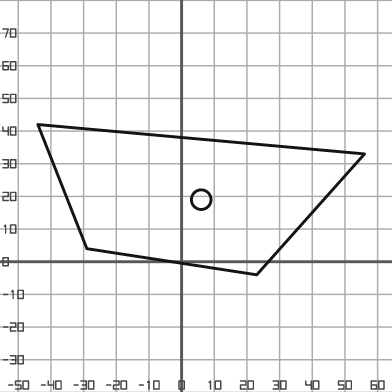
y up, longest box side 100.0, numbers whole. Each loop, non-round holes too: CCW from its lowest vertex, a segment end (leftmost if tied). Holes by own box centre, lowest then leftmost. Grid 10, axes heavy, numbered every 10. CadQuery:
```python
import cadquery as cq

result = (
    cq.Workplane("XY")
    .moveTo(23.0, -4.0)
    .lineTo(56.0, 33.0)
    .lineTo(-44.0, 42.0)
    .lineTo(-29.0, 4.0)
    .close()
    .moveTo(6.0, 19.0)
    .circle(3.0)
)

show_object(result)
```